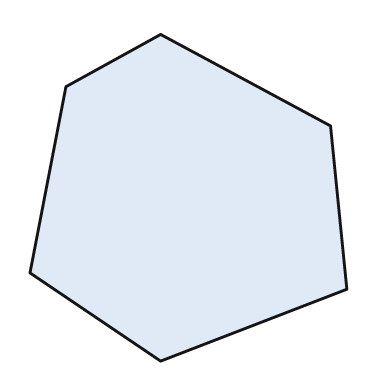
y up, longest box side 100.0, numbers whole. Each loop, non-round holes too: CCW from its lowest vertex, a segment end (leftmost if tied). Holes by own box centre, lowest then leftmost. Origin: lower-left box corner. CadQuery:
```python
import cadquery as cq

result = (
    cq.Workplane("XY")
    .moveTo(40.0, 0.0)
    .lineTo(97.0, 22.0)
    .lineTo(92.0, 72.0)
    .lineTo(40.0, 100.0)
    .lineTo(11.0, 84.0)
    .lineTo(0.0, 27.0)
    .close()
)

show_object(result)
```